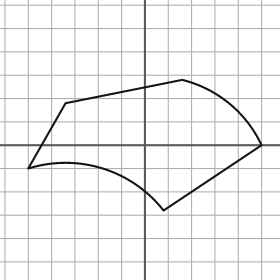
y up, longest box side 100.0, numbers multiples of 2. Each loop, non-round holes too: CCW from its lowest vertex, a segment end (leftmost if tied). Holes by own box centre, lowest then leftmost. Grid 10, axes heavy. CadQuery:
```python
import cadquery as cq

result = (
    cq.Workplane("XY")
    .moveTo(8.0, -28.0)
    .lineTo(50.0, 0.0)
    .threePointArc((36.0, 18.0), (16.0, 28.0))
    .lineTo(-34.0, 18.0)
    .lineTo(-50.0, -10.0)
    .threePointArc((-18.0, -10.0), (8.0, -28.0))
    .close()
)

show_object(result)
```